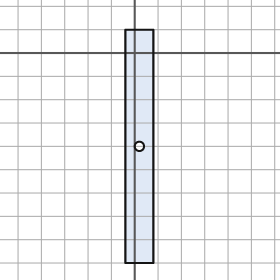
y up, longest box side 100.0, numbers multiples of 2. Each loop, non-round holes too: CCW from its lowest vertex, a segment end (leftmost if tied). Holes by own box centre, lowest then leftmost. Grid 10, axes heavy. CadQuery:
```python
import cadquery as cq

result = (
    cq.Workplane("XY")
    .moveTo(-4.0, -90.0)
    .lineTo(8.0, -90.0)
    .lineTo(8.0, 10.0)
    .lineTo(-4.0, 10.0)
    .close()
    .moveTo(2.0, -40.0)
    .circle(2.0)
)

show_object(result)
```